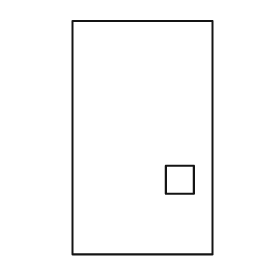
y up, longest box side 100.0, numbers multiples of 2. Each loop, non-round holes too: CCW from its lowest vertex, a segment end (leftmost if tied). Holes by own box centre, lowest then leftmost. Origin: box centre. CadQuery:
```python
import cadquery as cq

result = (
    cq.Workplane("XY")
    .moveTo(-30.0, -50.0)
    .lineTo(30.0, -50.0)
    .lineTo(30.0, 50.0)
    .lineTo(-30.0, 50.0)
    .close()
    .moveTo(10.0, -24.0)
    .lineTo(22.0, -24.0)
    .lineTo(22.0, -12.0)
    .lineTo(10.0, -12.0)
    .close()
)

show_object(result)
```